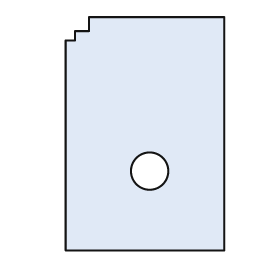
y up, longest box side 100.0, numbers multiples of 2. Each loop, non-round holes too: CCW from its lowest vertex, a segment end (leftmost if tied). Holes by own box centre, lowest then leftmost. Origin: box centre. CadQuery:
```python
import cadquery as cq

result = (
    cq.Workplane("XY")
    .moveTo(-34.0, -50.0)
    .lineTo(34.0, -50.0)
    .lineTo(34.0, 50.0)
    .lineTo(-24.0, 50.0)
    .lineTo(-24.0, 44.0)
    .lineTo(-30.0, 44.0)
    .lineTo(-30.0, 40.0)
    .lineTo(-34.0, 40.0)
    .close()
    .moveTo(2.0, -16.0)
    .circle(8.0)
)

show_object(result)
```